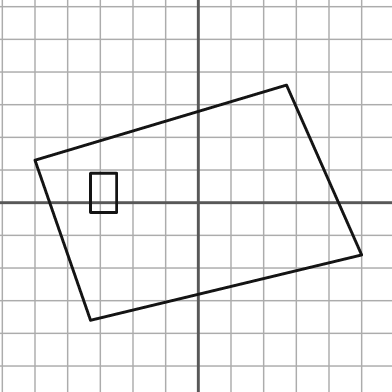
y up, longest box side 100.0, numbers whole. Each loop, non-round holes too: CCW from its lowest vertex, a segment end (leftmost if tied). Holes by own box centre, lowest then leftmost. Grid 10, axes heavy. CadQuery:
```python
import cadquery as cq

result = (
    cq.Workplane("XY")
    .moveTo(-33.0, -36.0)
    .lineTo(50.0, -16.0)
    .lineTo(27.0, 36.0)
    .lineTo(-50.0, 13.0)
    .close()
    .moveTo(-33.0, -3.0)
    .lineTo(-25.0, -3.0)
    .lineTo(-25.0, 9.0)
    .lineTo(-33.0, 9.0)
    .close()
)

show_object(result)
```